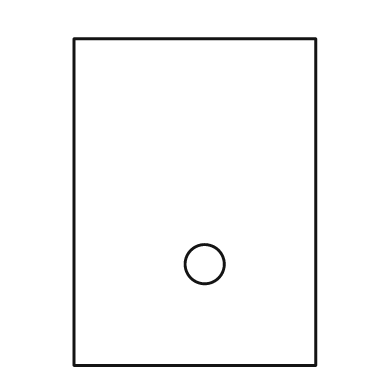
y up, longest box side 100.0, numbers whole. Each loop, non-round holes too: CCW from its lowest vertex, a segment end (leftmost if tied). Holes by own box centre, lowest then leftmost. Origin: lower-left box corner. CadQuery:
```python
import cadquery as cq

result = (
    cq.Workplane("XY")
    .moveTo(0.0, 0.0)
    .lineTo(74.0, 0.0)
    .lineTo(74.0, 100.0)
    .lineTo(0.0, 100.0)
    .close()
    .moveTo(40.0, 31.0)
    .circle(6.0)
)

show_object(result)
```